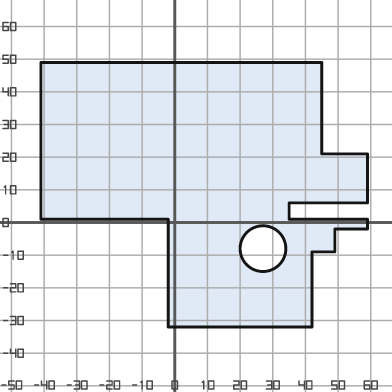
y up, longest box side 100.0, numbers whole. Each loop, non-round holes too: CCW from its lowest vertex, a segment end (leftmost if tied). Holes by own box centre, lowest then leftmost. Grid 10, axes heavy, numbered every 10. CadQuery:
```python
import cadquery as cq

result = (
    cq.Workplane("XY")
    .moveTo(-2.0, -32.0)
    .lineTo(42.0, -32.0)
    .lineTo(42.0, -9.0)
    .lineTo(49.0, -9.0)
    .lineTo(49.0, -2.0)
    .lineTo(59.0, -2.0)
    .lineTo(59.0, 1.0)
    .lineTo(35.0, 1.0)
    .lineTo(35.0, 6.0)
    .lineTo(59.0, 6.0)
    .lineTo(59.0, 21.0)
    .lineTo(45.0, 21.0)
    .lineTo(45.0, 49.0)
    .lineTo(-41.0, 49.0)
    .lineTo(-41.0, 1.0)
    .lineTo(-2.0, 1.0)
    .close()
    .moveTo(27.0, -8.0)
    .circle(7.0)
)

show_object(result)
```